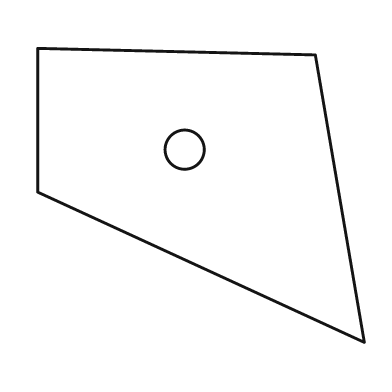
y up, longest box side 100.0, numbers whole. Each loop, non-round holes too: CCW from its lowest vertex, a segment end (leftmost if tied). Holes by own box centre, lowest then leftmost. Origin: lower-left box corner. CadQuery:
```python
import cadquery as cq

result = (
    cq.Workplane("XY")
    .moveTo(100.0, 0.0)
    .lineTo(85.0, 88.0)
    .lineTo(0.0, 90.0)
    .lineTo(0.0, 46.0)
    .close()
    .moveTo(45.0, 59.0)
    .circle(6.0)
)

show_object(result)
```